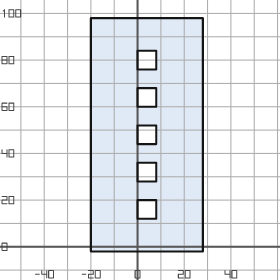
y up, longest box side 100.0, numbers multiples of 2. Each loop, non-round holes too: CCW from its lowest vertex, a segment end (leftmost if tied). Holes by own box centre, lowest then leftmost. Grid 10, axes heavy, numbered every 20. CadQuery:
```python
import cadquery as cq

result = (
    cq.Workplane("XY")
    .moveTo(-20.0, -2.0)
    .lineTo(28.0, -2.0)
    .lineTo(28.0, 98.0)
    .lineTo(-20.0, 98.0)
    .close()
    .moveTo(0.0, 12.0)
    .lineTo(8.0, 12.0)
    .lineTo(8.0, 20.0)
    .lineTo(0.0, 20.0)
    .close()
    .moveTo(0.0, 28.0)
    .lineTo(8.0, 28.0)
    .lineTo(8.0, 36.0)
    .lineTo(0.0, 36.0)
    .close()
    .moveTo(0.0, 44.0)
    .lineTo(8.0, 44.0)
    .lineTo(8.0, 52.0)
    .lineTo(0.0, 52.0)
    .close()
    .moveTo(0.0, 60.0)
    .lineTo(8.0, 60.0)
    .lineTo(8.0, 68.0)
    .lineTo(0.0, 68.0)
    .close()
    .moveTo(0.0, 76.0)
    .lineTo(8.0, 76.0)
    .lineTo(8.0, 84.0)
    .lineTo(0.0, 84.0)
    .close()
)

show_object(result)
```